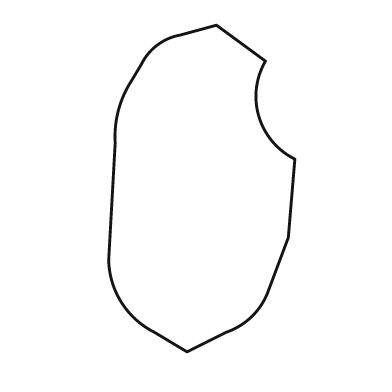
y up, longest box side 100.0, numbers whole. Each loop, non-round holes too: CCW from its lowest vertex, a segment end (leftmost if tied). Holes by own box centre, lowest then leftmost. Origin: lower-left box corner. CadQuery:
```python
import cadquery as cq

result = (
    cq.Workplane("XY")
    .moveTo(24.0, 0.0)
    .lineTo(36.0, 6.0)
    .threePointArc((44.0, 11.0), (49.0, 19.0))
    .lineTo(55.0, 35.0)
    .lineTo(57.0, 59.0)
    .threePointArc((46.0, 72.0), (48.0, 89.0))
    .lineTo(33.0, 100.0)
    .lineTo(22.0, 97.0)
    .threePointArc((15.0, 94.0), (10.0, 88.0))
    .lineTo(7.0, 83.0)
    .threePointArc((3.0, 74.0), (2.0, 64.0))
    .lineTo(0.0, 28.0)
    .threePointArc((4.0, 15.0), (14.0, 6.0))
    .close()
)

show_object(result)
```